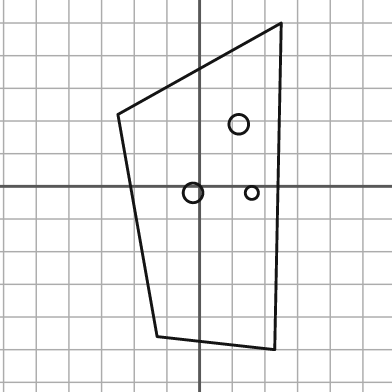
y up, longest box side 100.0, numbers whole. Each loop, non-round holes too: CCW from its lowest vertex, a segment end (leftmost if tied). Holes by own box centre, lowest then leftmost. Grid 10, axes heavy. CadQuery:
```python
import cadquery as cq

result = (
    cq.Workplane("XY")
    .moveTo(23.0, -50.0)
    .lineTo(25.0, 50.0)
    .lineTo(-25.0, 22.0)
    .lineTo(-13.0, -46.0)
    .close()
    .moveTo(-2.0, -2.0)
    .circle(3.0)
    .moveTo(16.0, -2.0)
    .circle(2.0)
    .moveTo(12.0, 19.0)
    .circle(3.0)
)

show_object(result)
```